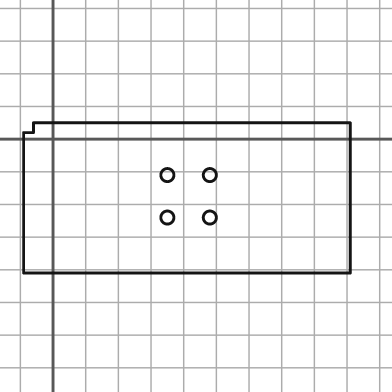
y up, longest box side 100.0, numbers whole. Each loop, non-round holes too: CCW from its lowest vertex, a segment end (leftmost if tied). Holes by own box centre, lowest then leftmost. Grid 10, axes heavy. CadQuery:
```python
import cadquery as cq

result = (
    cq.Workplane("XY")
    .moveTo(-9.0, -41.0)
    .lineTo(91.0, -41.0)
    .lineTo(91.0, 5.0)
    .lineTo(-6.0, 5.0)
    .lineTo(-6.0, 2.0)
    .lineTo(-9.0, 2.0)
    .close()
    .moveTo(35.0, -24.0)
    .circle(2.0)
    .moveTo(48.0, -24.0)
    .circle(2.0)
    .moveTo(35.0, -11.0)
    .circle(2.0)
    .moveTo(48.0, -11.0)
    .circle(2.0)
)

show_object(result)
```